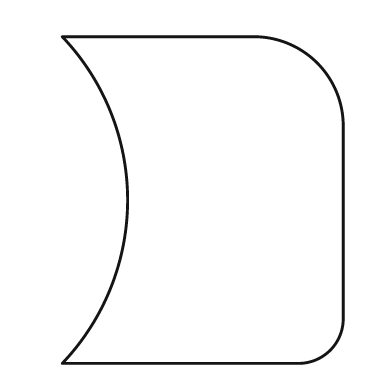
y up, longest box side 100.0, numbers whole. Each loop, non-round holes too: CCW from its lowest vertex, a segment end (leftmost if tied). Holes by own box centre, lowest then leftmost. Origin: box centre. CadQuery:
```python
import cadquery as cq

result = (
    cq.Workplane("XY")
    .moveTo(-43.0, -50.0)
    .lineTo(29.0, -50.0)
    .threePointArc((39.0, -46.0), (43.0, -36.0))
    .lineTo(43.0, 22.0)
    .threePointArc((35.0, 42.0), (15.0, 50.0))
    .lineTo(-43.0, 50.0)
    .threePointArc((-23.0, 0.0), (-43.0, -50.0))
    .close()
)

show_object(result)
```